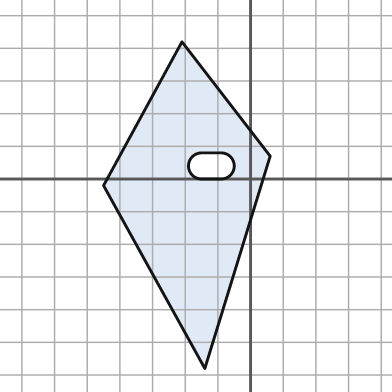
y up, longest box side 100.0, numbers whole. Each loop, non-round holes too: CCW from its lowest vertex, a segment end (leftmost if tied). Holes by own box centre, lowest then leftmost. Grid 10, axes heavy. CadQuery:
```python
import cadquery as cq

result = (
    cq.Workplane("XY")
    .moveTo(-14.0, -58.0)
    .lineTo(6.0, 7.0)
    .lineTo(-21.0, 42.0)
    .lineTo(-45.0, -2.0)
    .close()
    .moveTo(-15.0, 0.0)
    .lineTo(-9.0, 0.0)
    .threePointArc((-5.0, 4.0), (-9.0, 8.0))
    .lineTo(-15.0, 8.0)
    .threePointArc((-19.0, 4.0), (-15.0, 0.0))
    .close()
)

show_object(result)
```